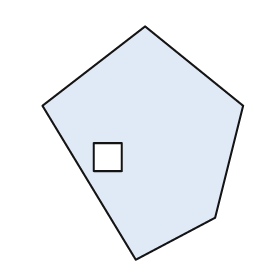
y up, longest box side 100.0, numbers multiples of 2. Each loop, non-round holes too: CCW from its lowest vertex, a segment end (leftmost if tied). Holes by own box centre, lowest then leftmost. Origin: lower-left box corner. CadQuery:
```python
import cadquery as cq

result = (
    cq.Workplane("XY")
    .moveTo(40.0, 0.0)
    .lineTo(74.0, 18.0)
    .lineTo(86.0, 66.0)
    .lineTo(44.0, 100.0)
    .lineTo(0.0, 66.0)
    .close()
    .moveTo(22.0, 38.0)
    .lineTo(34.0, 38.0)
    .lineTo(34.0, 50.0)
    .lineTo(22.0, 50.0)
    .close()
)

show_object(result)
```